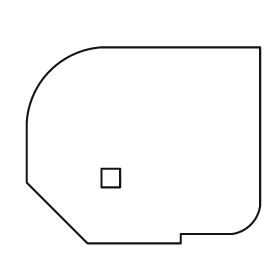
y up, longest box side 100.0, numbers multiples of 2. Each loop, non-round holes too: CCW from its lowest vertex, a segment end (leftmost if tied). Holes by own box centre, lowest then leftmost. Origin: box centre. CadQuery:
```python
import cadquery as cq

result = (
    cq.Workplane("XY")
    .moveTo(-24.0, -42.0)
    .lineTo(16.0, -42.0)
    .lineTo(16.0, -38.0)
    .lineTo(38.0, -38.0)
    .threePointArc((46.0, -34.0), (50.0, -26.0))
    .lineTo(50.0, 42.0)
    .lineTo(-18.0, 42.0)
    .threePointArc((-40.0, 32.0), (-50.0, 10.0))
    .lineTo(-50.0, -16.0)
    .close()
    .moveTo(-18.0, -18.0)
    .lineTo(-10.0, -18.0)
    .lineTo(-10.0, -10.0)
    .lineTo(-18.0, -10.0)
    .close()
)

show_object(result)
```